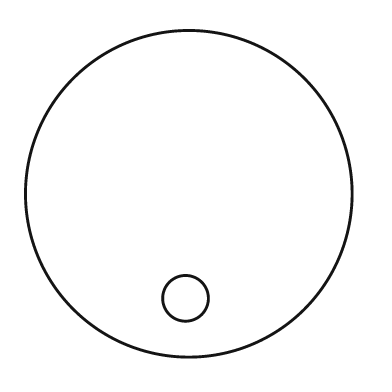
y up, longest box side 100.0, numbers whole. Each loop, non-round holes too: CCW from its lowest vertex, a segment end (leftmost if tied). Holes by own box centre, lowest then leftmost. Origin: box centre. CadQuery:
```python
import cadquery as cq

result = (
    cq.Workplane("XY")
    .moveTo(0.0, 0.0)
    .circle(50.0)
    .moveTo(-1.0, -32.0)
    .circle(7.0)
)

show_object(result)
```